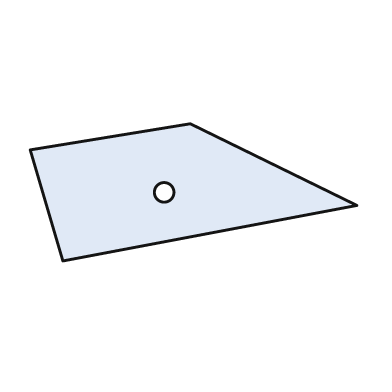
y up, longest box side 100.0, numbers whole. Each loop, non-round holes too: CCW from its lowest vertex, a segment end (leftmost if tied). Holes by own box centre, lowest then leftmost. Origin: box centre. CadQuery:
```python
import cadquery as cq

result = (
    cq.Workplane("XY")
    .moveTo(-40.0, -21.0)
    .lineTo(50.0, -4.0)
    .lineTo(-1.0, 21.0)
    .lineTo(-50.0, 13.0)
    .close()
    .moveTo(-9.0, 0.0)
    .circle(3.0)
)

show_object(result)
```